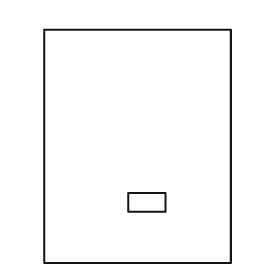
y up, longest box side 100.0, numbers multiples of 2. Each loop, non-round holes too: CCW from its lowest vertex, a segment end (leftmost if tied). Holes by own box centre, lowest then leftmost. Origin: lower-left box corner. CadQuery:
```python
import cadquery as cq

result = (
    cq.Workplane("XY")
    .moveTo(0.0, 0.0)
    .lineTo(80.0, 0.0)
    .lineTo(80.0, 100.0)
    .lineTo(0.0, 100.0)
    .close()
    .moveTo(36.0, 22.0)
    .lineTo(52.0, 22.0)
    .lineTo(52.0, 30.0)
    .lineTo(36.0, 30.0)
    .close()
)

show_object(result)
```